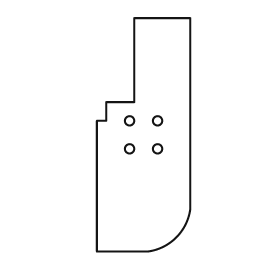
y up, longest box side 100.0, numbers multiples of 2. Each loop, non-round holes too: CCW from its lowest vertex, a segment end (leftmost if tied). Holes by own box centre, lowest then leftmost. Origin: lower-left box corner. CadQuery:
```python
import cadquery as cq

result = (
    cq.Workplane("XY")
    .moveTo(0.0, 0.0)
    .lineTo(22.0, 0.0)
    .threePointArc((34.0, 6.0), (40.0, 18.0))
    .lineTo(40.0, 100.0)
    .lineTo(16.0, 100.0)
    .lineTo(16.0, 64.0)
    .lineTo(4.0, 64.0)
    .lineTo(4.0, 56.0)
    .lineTo(0.0, 56.0)
    .close()
    .moveTo(14.0, 44.0)
    .circle(2.0)
    .moveTo(26.0, 44.0)
    .circle(2.0)
    .moveTo(14.0, 56.0)
    .circle(2.0)
    .moveTo(26.0, 56.0)
    .circle(2.0)
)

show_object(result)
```